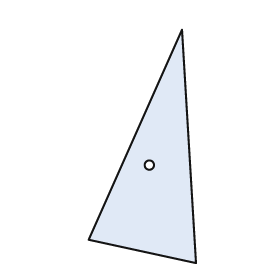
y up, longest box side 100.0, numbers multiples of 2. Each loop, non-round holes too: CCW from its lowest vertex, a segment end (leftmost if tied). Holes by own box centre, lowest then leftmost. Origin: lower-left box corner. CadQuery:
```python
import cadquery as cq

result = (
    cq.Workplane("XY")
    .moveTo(46.0, 0.0)
    .lineTo(40.0, 100.0)
    .lineTo(0.0, 10.0)
    .close()
    .moveTo(26.0, 42.0)
    .circle(2.0)
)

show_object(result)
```